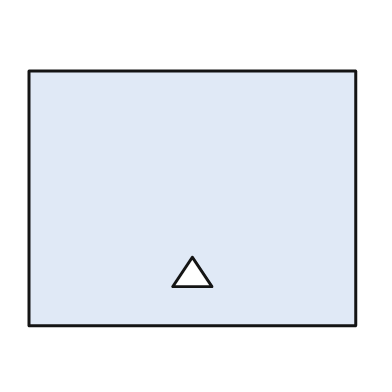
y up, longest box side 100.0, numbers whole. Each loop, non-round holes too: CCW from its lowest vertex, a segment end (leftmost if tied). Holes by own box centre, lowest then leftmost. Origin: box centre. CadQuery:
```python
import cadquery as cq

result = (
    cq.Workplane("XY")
    .moveTo(-50.0, -39.0)
    .lineTo(50.0, -39.0)
    .lineTo(50.0, 39.0)
    .lineTo(-50.0, 39.0)
    .close()
    .moveTo(-6.0, -27.0)
    .lineTo(6.0, -27.0)
    .lineTo(0.0, -18.0)
    .close()
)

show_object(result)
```